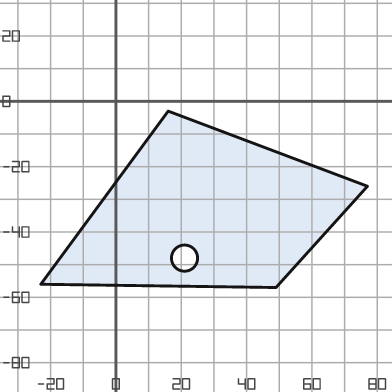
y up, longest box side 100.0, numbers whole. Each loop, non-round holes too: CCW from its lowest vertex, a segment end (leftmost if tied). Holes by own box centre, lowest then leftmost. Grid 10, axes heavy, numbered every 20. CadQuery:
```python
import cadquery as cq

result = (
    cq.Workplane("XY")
    .moveTo(49.0, -57.0)
    .lineTo(77.0, -26.0)
    .lineTo(16.0, -3.0)
    .lineTo(-23.0, -56.0)
    .close()
    .moveTo(21.0, -48.0)
    .circle(4.0)
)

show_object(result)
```